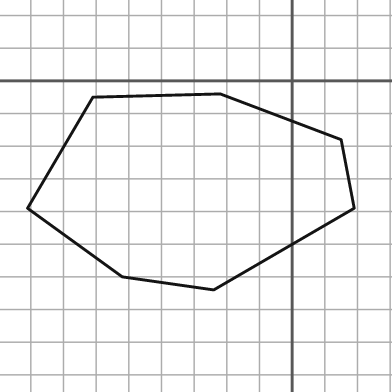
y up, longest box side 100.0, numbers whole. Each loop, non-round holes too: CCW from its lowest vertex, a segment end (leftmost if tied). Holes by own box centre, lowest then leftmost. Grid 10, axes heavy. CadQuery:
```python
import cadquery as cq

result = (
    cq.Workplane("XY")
    .moveTo(-24.0, -64.0)
    .lineTo(19.0, -39.0)
    .lineTo(15.0, -18.0)
    .lineTo(-22.0, -4.0)
    .lineTo(-61.0, -5.0)
    .lineTo(-81.0, -39.0)
    .lineTo(-52.0, -60.0)
    .close()
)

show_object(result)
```